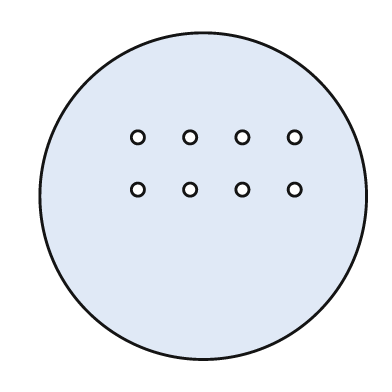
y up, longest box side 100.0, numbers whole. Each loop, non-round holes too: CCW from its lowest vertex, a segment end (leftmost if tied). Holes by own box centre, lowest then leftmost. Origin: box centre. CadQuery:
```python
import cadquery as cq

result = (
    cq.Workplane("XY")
    .moveTo(0.0, 0.0)
    .circle(50.0)
    .moveTo(-20.0, 2.0)
    .circle(2.0)
    .moveTo(-4.0, 2.0)
    .circle(2.0)
    .moveTo(12.0, 2.0)
    .circle(2.0)
    .moveTo(28.0, 2.0)
    .circle(2.0)
    .moveTo(-20.0, 18.0)
    .circle(2.0)
    .moveTo(-4.0, 18.0)
    .circle(2.0)
    .moveTo(12.0, 18.0)
    .circle(2.0)
    .moveTo(28.0, 18.0)
    .circle(2.0)
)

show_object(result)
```